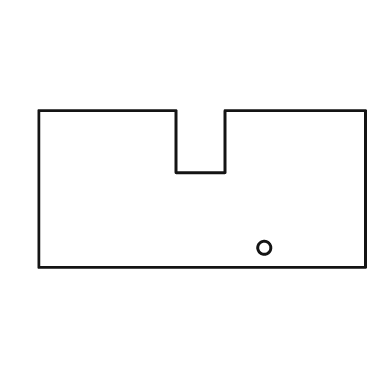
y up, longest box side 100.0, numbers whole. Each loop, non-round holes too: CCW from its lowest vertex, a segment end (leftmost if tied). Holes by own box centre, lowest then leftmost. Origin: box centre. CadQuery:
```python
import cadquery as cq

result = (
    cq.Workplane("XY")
    .moveTo(-50.0, -24.0)
    .lineTo(50.0, -24.0)
    .lineTo(50.0, 24.0)
    .lineTo(7.0, 24.0)
    .lineTo(7.0, 5.0)
    .lineTo(-8.0, 5.0)
    .lineTo(-8.0, 24.0)
    .lineTo(-50.0, 24.0)
    .close()
    .moveTo(19.0, -18.0)
    .circle(2.0)
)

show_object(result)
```